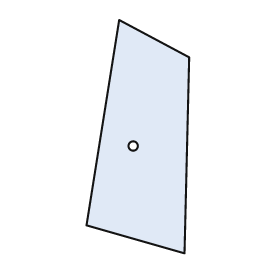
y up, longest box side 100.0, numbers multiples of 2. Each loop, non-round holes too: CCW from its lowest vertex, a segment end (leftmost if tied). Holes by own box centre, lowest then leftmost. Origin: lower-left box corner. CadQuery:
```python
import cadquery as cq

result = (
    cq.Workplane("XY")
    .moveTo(42.0, 0.0)
    .lineTo(44.0, 84.0)
    .lineTo(14.0, 100.0)
    .lineTo(0.0, 12.0)
    .close()
    .moveTo(20.0, 46.0)
    .circle(2.0)
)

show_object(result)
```